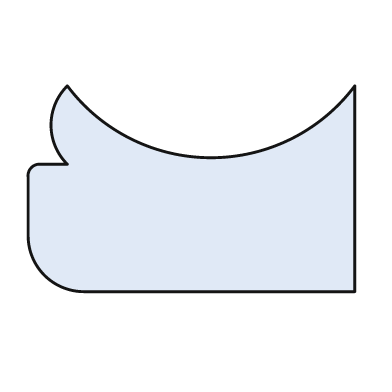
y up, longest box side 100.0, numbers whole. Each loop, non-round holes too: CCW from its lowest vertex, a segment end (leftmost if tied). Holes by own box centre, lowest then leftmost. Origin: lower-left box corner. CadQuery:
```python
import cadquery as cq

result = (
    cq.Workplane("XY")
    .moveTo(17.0, 0.0)
    .lineTo(100.0, 0.0)
    .lineTo(100.0, 63.0)
    .threePointArc((56.0, 41.0), (12.0, 63.0))
    .threePointArc((7.0, 51.0), (12.0, 39.0))
    .lineTo(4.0, 39.0)
    .threePointArc((1.0, 38.0), (0.0, 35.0))
    .lineTo(0.0, 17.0)
    .threePointArc((5.0, 5.0), (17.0, 0.0))
    .close()
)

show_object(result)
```